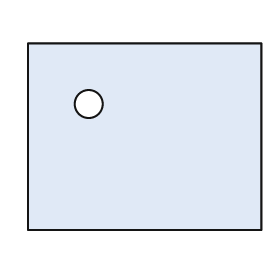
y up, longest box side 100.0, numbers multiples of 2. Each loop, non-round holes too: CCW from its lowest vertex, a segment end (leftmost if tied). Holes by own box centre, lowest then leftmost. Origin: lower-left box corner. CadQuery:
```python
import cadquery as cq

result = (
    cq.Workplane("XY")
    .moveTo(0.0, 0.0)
    .lineTo(100.0, 0.0)
    .lineTo(100.0, 80.0)
    .lineTo(0.0, 80.0)
    .close()
    .moveTo(26.0, 54.0)
    .circle(6.0)
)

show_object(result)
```